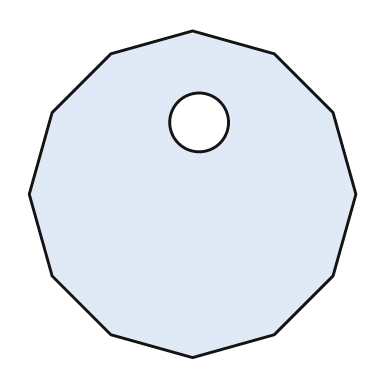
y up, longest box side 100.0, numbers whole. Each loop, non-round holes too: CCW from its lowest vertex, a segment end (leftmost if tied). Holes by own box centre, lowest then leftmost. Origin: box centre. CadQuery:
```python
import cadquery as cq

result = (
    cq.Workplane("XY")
    .moveTo(0.0, -50.0)
    .lineTo(25.0, -43.0)
    .lineTo(43.0, -25.0)
    .lineTo(50.0, 0.0)
    .lineTo(43.0, 25.0)
    .lineTo(25.0, 43.0)
    .lineTo(0.0, 50.0)
    .lineTo(-25.0, 43.0)
    .lineTo(-43.0, 25.0)
    .lineTo(-50.0, 0.0)
    .lineTo(-43.0, -25.0)
    .lineTo(-25.0, -43.0)
    .close()
    .moveTo(2.0, 22.0)
    .circle(9.0)
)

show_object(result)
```